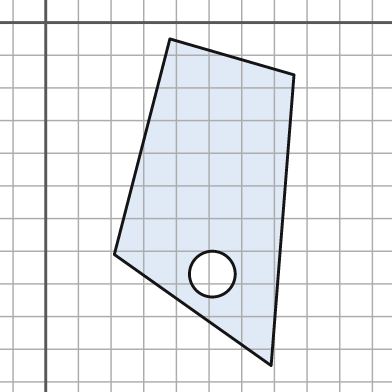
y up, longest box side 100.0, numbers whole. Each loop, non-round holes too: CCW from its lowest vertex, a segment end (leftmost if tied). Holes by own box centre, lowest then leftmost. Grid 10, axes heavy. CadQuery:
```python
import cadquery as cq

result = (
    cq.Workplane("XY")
    .moveTo(69.0, -105.0)
    .lineTo(76.0, -16.0)
    .lineTo(38.0, -5.0)
    .lineTo(21.0, -71.0)
    .close()
    .moveTo(51.0, -77.0)
    .circle(7.0)
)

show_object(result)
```